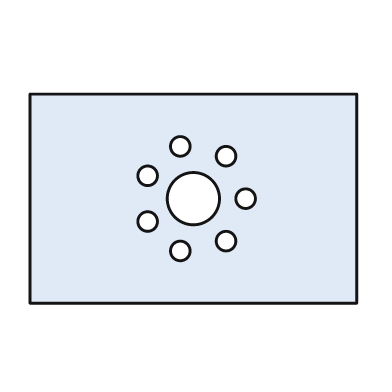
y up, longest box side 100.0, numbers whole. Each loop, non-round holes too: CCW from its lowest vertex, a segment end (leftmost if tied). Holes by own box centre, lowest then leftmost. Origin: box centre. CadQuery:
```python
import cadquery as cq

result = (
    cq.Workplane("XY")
    .moveTo(-50.0, -32.0)
    .lineTo(50.0, -32.0)
    .lineTo(50.0, 32.0)
    .lineTo(-50.0, 32.0)
    .close()
    .moveTo(-4.0, -16.0)
    .circle(3.0)
    .moveTo(10.0, -13.0)
    .circle(3.0)
    .moveTo(-14.0, -7.0)
    .circle(3.0)
    .moveTo(0.0, 0.0)
    .circle(8.0)
    .moveTo(16.0, 0.0)
    .circle(3.0)
    .moveTo(-14.0, 7.0)
    .circle(3.0)
    .moveTo(10.0, 13.0)
    .circle(3.0)
    .moveTo(-4.0, 16.0)
    .circle(3.0)
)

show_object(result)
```